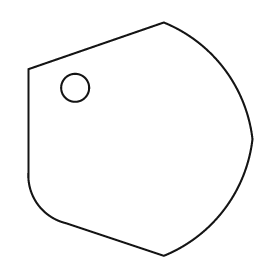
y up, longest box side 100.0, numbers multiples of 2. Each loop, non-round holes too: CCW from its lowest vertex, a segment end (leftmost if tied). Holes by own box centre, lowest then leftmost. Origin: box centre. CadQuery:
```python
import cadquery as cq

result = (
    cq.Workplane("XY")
    .moveTo(10.0, -50.0)
    .threePointArc((36.0, -30.0), (48.0, 0.0))
    .threePointArc((36.0, 30.0), (10.0, 50.0))
    .lineTo(-48.0, 30.0)
    .lineTo(-48.0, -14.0)
    .threePointArc((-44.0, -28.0), (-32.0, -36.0))
    .close()
    .moveTo(-28.0, 22.0)
    .circle(6.0)
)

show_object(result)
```